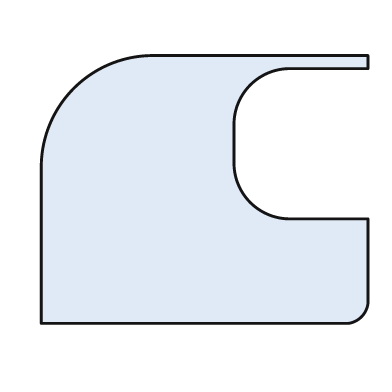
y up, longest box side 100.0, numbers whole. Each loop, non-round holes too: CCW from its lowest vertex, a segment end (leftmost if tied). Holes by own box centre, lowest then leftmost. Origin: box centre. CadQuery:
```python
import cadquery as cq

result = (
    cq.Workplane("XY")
    .moveTo(-50.0, -41.0)
    .lineTo(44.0, -41.0)
    .threePointArc((48.0, -39.0), (50.0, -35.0))
    .lineTo(50.0, -9.0)
    .lineTo(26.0, -9.0)
    .threePointArc((14.0, -4.0), (9.0, 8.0))
    .lineTo(9.0, 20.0)
    .threePointArc((14.0, 32.0), (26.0, 37.0))
    .lineTo(50.0, 37.0)
    .lineTo(50.0, 41.0)
    .lineTo(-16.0, 41.0)
    .threePointArc((-40.0, 31.0), (-50.0, 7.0))
    .close()
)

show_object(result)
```